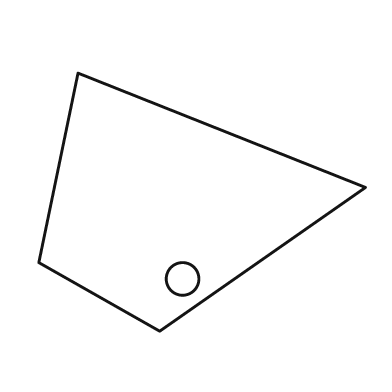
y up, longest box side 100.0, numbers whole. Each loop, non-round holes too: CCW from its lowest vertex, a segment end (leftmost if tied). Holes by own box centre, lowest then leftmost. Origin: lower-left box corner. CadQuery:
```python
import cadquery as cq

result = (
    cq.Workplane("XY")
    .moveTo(37.0, 0.0)
    .lineTo(100.0, 44.0)
    .lineTo(12.0, 79.0)
    .lineTo(0.0, 21.0)
    .close()
    .moveTo(44.0, 16.0)
    .circle(5.0)
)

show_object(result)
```